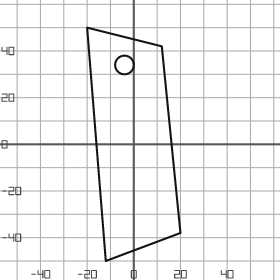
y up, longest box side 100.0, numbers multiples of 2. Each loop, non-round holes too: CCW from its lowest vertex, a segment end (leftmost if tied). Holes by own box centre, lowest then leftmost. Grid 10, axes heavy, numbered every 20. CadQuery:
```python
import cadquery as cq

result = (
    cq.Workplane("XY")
    .moveTo(-12.0, -50.0)
    .lineTo(20.0, -38.0)
    .lineTo(12.0, 42.0)
    .lineTo(-20.0, 50.0)
    .close()
    .moveTo(-4.0, 34.0)
    .circle(4.0)
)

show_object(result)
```